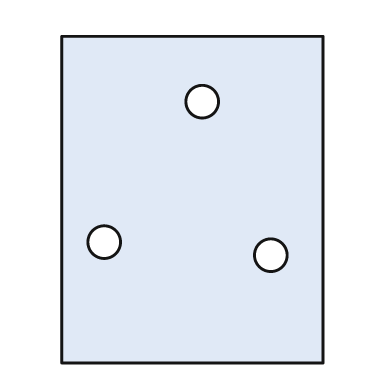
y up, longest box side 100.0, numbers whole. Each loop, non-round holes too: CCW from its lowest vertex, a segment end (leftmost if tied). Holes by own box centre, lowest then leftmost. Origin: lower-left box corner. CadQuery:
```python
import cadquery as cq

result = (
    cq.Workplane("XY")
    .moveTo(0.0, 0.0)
    .lineTo(80.0, 0.0)
    .lineTo(80.0, 100.0)
    .lineTo(0.0, 100.0)
    .close()
    .moveTo(64.0, 33.0)
    .circle(5.0)
    .moveTo(13.0, 37.0)
    .circle(5.0)
    .moveTo(43.0, 80.0)
    .circle(5.0)
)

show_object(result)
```